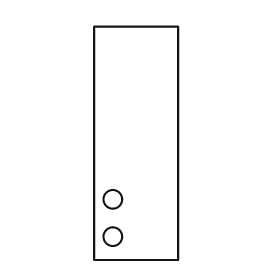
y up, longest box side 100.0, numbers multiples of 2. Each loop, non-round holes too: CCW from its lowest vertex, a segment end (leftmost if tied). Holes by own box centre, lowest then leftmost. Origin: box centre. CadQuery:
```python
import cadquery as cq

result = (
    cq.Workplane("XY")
    .moveTo(-18.0, -50.0)
    .lineTo(18.0, -50.0)
    .lineTo(18.0, 50.0)
    .lineTo(-18.0, 50.0)
    .close()
    .moveTo(-10.0, -40.0)
    .circle(4.0)
    .moveTo(-10.0, -24.0)
    .circle(4.0)
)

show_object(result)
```